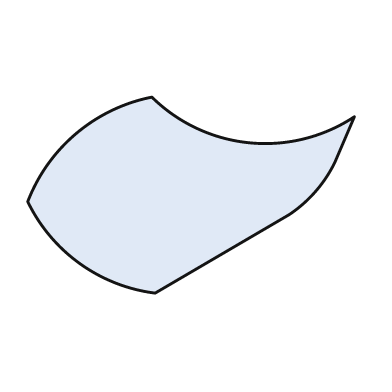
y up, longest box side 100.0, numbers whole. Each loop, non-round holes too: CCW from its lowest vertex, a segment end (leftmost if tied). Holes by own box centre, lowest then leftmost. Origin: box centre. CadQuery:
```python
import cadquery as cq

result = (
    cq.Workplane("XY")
    .moveTo(-11.0, -30.0)
    .lineTo(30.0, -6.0)
    .threePointArc((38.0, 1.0), (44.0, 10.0))
    .lineTo(50.0, 24.0)
    .threePointArc((18.0, 16.0), (-12.0, 30.0))
    .threePointArc((-35.0, 19.0), (-50.0, -2.0))
    .threePointArc((-34.0, -21.0), (-11.0, -30.0))
    .close()
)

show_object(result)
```